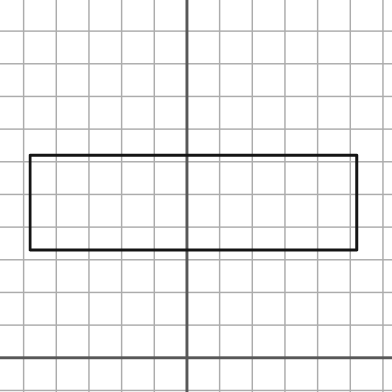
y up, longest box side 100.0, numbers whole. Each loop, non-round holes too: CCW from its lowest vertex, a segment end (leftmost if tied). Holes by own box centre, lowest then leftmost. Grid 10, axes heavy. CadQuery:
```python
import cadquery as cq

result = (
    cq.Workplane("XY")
    .moveTo(-48.0, 33.0)
    .lineTo(52.0, 33.0)
    .lineTo(52.0, 62.0)
    .lineTo(-48.0, 62.0)
    .close()
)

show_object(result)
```